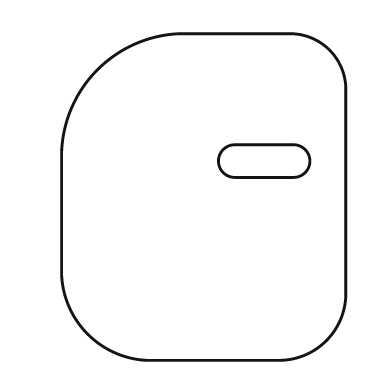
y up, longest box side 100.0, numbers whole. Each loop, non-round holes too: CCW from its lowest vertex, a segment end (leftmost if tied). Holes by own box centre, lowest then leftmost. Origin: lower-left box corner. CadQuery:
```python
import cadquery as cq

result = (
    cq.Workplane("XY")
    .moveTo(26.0, 0.0)
    .lineTo(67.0, 0.0)
    .threePointArc((81.0, 6.0), (87.0, 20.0))
    .lineTo(87.0, 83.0)
    .threePointArc((82.0, 95.0), (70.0, 100.0))
    .lineTo(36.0, 100.0)
    .threePointArc((11.0, 89.0), (0.0, 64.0))
    .lineTo(0.0, 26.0)
    .threePointArc((8.0, 8.0), (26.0, 0.0))
    .close()
    .moveTo(53.0, 56.0)
    .lineTo(71.0, 56.0)
    .threePointArc((76.0, 61.0), (71.0, 66.0))
    .lineTo(53.0, 66.0)
    .threePointArc((48.0, 61.0), (53.0, 56.0))
    .close()
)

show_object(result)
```